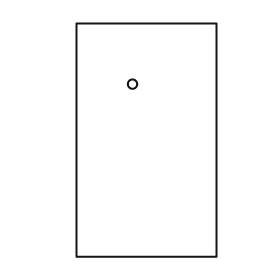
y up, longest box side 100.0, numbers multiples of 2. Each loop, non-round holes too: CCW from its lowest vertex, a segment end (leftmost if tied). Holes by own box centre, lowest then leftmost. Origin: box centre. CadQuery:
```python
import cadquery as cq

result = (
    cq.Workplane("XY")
    .moveTo(-30.0, -50.0)
    .lineTo(30.0, -50.0)
    .lineTo(30.0, 50.0)
    .lineTo(-30.0, 50.0)
    .close()
    .moveTo(-6.0, 24.0)
    .circle(2.0)
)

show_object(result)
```